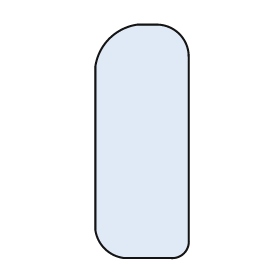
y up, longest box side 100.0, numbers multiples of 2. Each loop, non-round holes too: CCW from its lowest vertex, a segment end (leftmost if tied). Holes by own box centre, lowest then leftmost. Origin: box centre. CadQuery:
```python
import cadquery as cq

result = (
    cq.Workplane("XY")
    .moveTo(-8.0, -50.0)
    .lineTo(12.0, -50.0)
    .threePointArc((18.0, -48.0), (20.0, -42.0))
    .lineTo(20.0, 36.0)
    .threePointArc((16.0, 46.0), (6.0, 50.0))
    .lineTo(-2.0, 50.0)
    .threePointArc((-14.0, 44.0), (-20.0, 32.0))
    .lineTo(-20.0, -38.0)
    .threePointArc((-16.0, -46.0), (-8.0, -50.0))
    .close()
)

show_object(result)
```